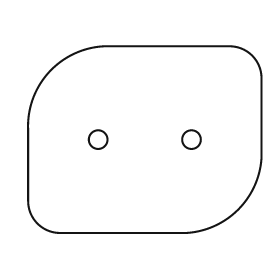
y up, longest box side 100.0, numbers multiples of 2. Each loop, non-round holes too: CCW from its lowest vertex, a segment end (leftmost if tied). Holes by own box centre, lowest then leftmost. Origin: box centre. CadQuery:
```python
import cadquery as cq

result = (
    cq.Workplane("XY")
    .moveTo(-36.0, -40.0)
    .lineTo(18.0, -40.0)
    .threePointArc((40.0, -30.0), (50.0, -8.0))
    .lineTo(50.0, 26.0)
    .threePointArc((46.0, 36.0), (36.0, 40.0))
    .lineTo(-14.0, 40.0)
    .threePointArc((-40.0, 30.0), (-50.0, 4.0))
    .lineTo(-50.0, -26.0)
    .threePointArc((-46.0, -36.0), (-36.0, -40.0))
    .close()
    .moveTo(-20.0, 0.0)
    .circle(4.0)
    .moveTo(20.0, 0.0)
    .circle(4.0)
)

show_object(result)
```